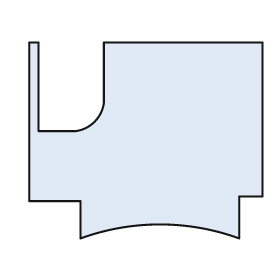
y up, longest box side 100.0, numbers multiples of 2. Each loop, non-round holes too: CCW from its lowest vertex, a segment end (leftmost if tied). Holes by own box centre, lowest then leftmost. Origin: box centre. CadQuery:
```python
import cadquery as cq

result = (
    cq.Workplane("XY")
    .moveTo(-28.0, -42.0)
    .threePointArc((6.0, -36.0), (40.0, -42.0))
    .lineTo(40.0, -24.0)
    .lineTo(50.0, -24.0)
    .lineTo(50.0, 42.0)
    .lineTo(-18.0, 42.0)
    .lineTo(-18.0, 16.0)
    .threePointArc((-22.0, 8.0), (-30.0, 4.0))
    .lineTo(-46.0, 4.0)
    .lineTo(-46.0, 42.0)
    .lineTo(-50.0, 42.0)
    .lineTo(-50.0, -26.0)
    .lineTo(-28.0, -26.0)
    .close()
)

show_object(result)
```